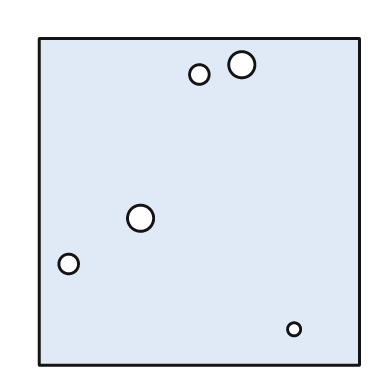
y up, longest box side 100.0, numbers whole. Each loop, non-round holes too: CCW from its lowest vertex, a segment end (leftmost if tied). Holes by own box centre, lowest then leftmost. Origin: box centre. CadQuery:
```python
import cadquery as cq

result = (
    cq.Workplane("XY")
    .moveTo(-49.0, -50.0)
    .lineTo(49.0, -50.0)
    .lineTo(49.0, 50.0)
    .lineTo(-49.0, 50.0)
    .close()
    .moveTo(29.0, -39.0)
    .circle(2.0)
    .moveTo(-40.0, -19.0)
    .circle(3.0)
    .moveTo(-18.0, -5.0)
    .circle(4.0)
    .moveTo(0.0, 39.0)
    .circle(3.0)
    .moveTo(13.0, 42.0)
    .circle(4.0)
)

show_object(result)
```